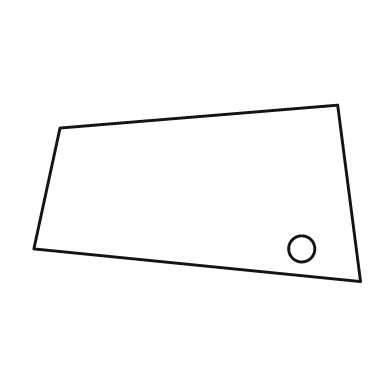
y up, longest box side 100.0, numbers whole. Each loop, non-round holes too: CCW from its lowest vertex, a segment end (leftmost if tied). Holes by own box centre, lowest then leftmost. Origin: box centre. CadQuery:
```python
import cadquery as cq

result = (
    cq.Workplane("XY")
    .moveTo(50.0, -27.0)
    .lineTo(43.0, 27.0)
    .lineTo(-42.0, 20.0)
    .lineTo(-50.0, -17.0)
    .close()
    .moveTo(32.0, -17.0)
    .circle(4.0)
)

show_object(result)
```